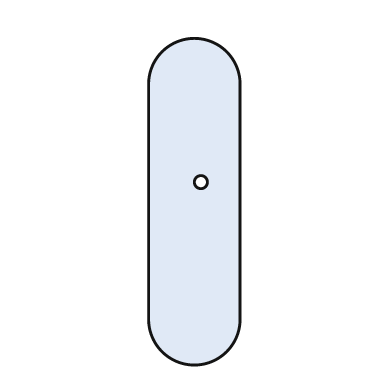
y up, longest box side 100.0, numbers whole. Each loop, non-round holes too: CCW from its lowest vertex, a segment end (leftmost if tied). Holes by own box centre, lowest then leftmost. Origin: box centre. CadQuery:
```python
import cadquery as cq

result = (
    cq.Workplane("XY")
    .moveTo(-14.0, -36.0)
    .threePointArc((0.0, -50.0), (14.0, -36.0))
    .lineTo(14.0, 36.0)
    .threePointArc((0.0, 50.0), (-14.0, 36.0))
    .close()
    .moveTo(2.0, 6.0)
    .circle(2.0)
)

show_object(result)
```